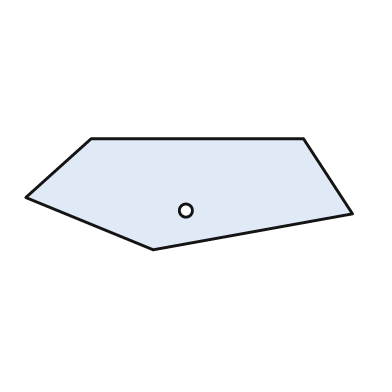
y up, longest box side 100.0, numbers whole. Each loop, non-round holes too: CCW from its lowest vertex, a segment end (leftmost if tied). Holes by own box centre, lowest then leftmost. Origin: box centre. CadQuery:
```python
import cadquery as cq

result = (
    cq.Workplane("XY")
    .moveTo(-11.0, -17.0)
    .lineTo(50.0, -6.0)
    .lineTo(35.0, 17.0)
    .lineTo(-30.0, 17.0)
    .lineTo(-50.0, -1.0)
    .close()
    .moveTo(-1.0, -5.0)
    .circle(2.0)
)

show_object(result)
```